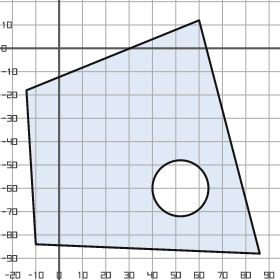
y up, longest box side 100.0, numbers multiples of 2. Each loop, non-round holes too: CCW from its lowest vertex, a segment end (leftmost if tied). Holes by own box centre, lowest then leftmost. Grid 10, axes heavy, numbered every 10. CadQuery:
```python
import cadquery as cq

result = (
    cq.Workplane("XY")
    .moveTo(86.0, -88.0)
    .lineTo(60.0, 12.0)
    .lineTo(-14.0, -18.0)
    .lineTo(-10.0, -84.0)
    .close()
    .moveTo(52.0, -60.0)
    .circle(12.0)
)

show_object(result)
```